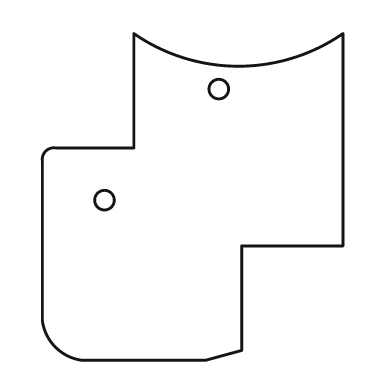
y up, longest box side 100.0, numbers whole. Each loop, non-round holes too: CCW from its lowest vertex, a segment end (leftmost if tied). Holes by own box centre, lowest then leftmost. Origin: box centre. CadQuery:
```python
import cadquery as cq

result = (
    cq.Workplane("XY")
    .moveTo(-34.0, -50.0)
    .lineTo(4.0, -50.0)
    .lineTo(15.0, -47.0)
    .lineTo(15.0, -15.0)
    .lineTo(46.0, -15.0)
    .lineTo(46.0, 50.0)
    .threePointArc((14.0, 40.0), (-18.0, 50.0))
    .lineTo(-18.0, 15.0)
    .lineTo(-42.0, 15.0)
    .threePointArc((-45.0, 14.0), (-46.0, 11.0))
    .lineTo(-46.0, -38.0)
    .threePointArc((-42.0, -46.0), (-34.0, -50.0))
    .close()
    .moveTo(-27.0, -1.0)
    .circle(3.0)
    .moveTo(8.0, 33.0)
    .circle(3.0)
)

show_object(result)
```